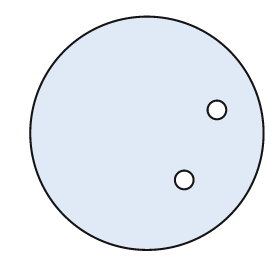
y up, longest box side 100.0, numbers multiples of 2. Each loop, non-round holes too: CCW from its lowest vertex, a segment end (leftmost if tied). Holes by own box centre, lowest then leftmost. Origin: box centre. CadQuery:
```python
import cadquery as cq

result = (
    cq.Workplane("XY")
    .moveTo(0.0, 0.0)
    .circle(50.0)
    .moveTo(16.0, -20.0)
    .circle(4.0)
    .moveTo(30.0, 10.0)
    .circle(4.0)
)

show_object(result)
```